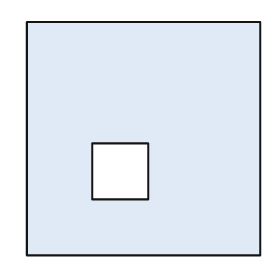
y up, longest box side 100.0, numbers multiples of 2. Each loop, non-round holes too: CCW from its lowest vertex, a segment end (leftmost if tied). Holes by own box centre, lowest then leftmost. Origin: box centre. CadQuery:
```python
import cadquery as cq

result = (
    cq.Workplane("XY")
    .moveTo(-50.0, -50.0)
    .lineTo(50.0, -50.0)
    .lineTo(50.0, 50.0)
    .lineTo(-50.0, 50.0)
    .close()
    .moveTo(-22.0, -26.0)
    .lineTo(2.0, -26.0)
    .lineTo(2.0, -2.0)
    .lineTo(-22.0, -2.0)
    .close()
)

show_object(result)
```